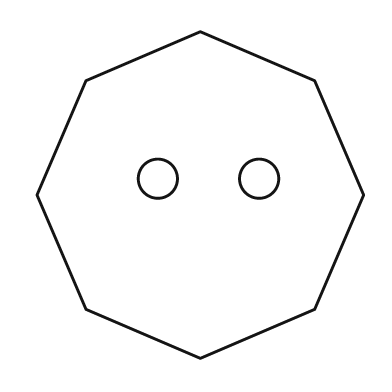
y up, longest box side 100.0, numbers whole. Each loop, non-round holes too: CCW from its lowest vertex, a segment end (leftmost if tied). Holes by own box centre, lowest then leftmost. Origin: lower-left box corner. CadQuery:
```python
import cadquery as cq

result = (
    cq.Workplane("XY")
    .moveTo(50.0, 0.0)
    .lineTo(85.0, 15.0)
    .lineTo(100.0, 50.0)
    .lineTo(85.0, 85.0)
    .lineTo(50.0, 100.0)
    .lineTo(15.0, 85.0)
    .lineTo(0.0, 50.0)
    .lineTo(15.0, 15.0)
    .close()
    .moveTo(37.0, 55.0)
    .circle(6.0)
    .moveTo(68.0, 55.0)
    .circle(6.0)
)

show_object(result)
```